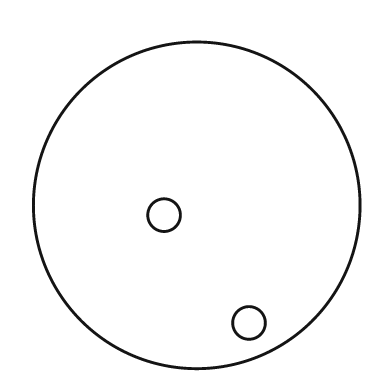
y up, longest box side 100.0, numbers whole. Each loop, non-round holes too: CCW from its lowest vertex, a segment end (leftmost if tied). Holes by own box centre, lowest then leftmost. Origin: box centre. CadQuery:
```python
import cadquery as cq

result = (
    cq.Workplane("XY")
    .moveTo(0.0, 0.0)
    .circle(50.0)
    .moveTo(16.0, -36.0)
    .circle(5.0)
    .moveTo(-10.0, -3.0)
    .circle(5.0)
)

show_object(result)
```